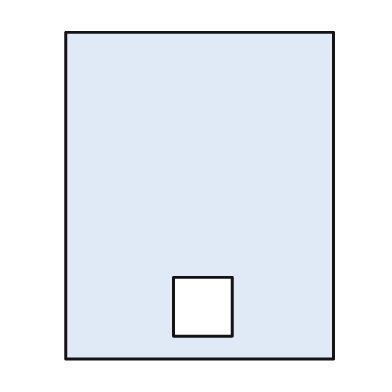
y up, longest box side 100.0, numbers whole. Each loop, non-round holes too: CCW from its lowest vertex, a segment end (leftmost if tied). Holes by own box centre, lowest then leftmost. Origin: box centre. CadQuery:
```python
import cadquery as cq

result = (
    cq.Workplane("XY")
    .moveTo(-41.0, -50.0)
    .lineTo(41.0, -50.0)
    .lineTo(41.0, 50.0)
    .lineTo(-41.0, 50.0)
    .close()
    .moveTo(-8.0, -43.0)
    .lineTo(10.0, -43.0)
    .lineTo(10.0, -25.0)
    .lineTo(-8.0, -25.0)
    .close()
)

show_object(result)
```